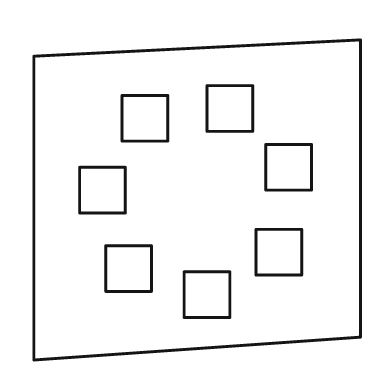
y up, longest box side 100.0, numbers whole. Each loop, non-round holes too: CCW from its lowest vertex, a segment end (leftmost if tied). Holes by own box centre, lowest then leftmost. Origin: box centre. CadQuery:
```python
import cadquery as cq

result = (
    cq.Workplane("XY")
    .moveTo(-50.0, -49.0)
    .lineTo(50.0, -42.0)
    .lineTo(50.0, 49.0)
    .lineTo(-50.0, 44.0)
    .close()
    .moveTo(-4.0, -36.0)
    .lineTo(10.0, -36.0)
    .lineTo(10.0, -22.0)
    .lineTo(-4.0, -22.0)
    .close()
    .moveTo(-28.0, -28.0)
    .lineTo(-14.0, -28.0)
    .lineTo(-14.0, -14.0)
    .lineTo(-28.0, -14.0)
    .close()
    .moveTo(18.0, -23.0)
    .lineTo(32.0, -23.0)
    .lineTo(32.0, -9.0)
    .lineTo(18.0, -9.0)
    .close()
    .moveTo(-36.0, -4.0)
    .lineTo(-22.0, -4.0)
    .lineTo(-22.0, 10.0)
    .lineTo(-36.0, 10.0)
    .close()
    .moveTo(21.0, 3.0)
    .lineTo(35.0, 3.0)
    .lineTo(35.0, 17.0)
    .lineTo(21.0, 17.0)
    .close()
    .moveTo(-23.0, 18.0)
    .lineTo(-9.0, 18.0)
    .lineTo(-9.0, 32.0)
    .lineTo(-23.0, 32.0)
    .close()
    .moveTo(3.0, 21.0)
    .lineTo(17.0, 21.0)
    .lineTo(17.0, 35.0)
    .lineTo(3.0, 35.0)
    .close()
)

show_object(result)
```